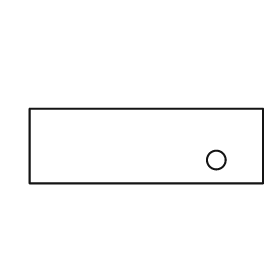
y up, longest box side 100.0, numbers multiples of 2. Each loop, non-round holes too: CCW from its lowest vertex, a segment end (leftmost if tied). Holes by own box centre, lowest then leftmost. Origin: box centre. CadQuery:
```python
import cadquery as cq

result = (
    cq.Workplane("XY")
    .moveTo(-50.0, -16.0)
    .lineTo(50.0, -16.0)
    .lineTo(50.0, 16.0)
    .lineTo(-50.0, 16.0)
    .close()
    .moveTo(30.0, -6.0)
    .circle(4.0)
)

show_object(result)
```